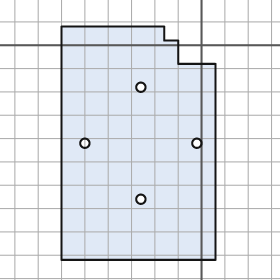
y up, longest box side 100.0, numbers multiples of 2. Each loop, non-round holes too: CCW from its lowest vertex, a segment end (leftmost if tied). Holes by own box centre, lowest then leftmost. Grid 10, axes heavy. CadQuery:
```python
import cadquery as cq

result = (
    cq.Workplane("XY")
    .moveTo(-60.0, -92.0)
    .lineTo(6.0, -92.0)
    .lineTo(6.0, -8.0)
    .lineTo(-10.0, -8.0)
    .lineTo(-10.0, 2.0)
    .lineTo(-16.0, 2.0)
    .lineTo(-16.0, 8.0)
    .lineTo(-60.0, 8.0)
    .close()
    .moveTo(-26.0, -66.0)
    .circle(2.0)
    .moveTo(-50.0, -42.0)
    .circle(2.0)
    .moveTo(-2.0, -42.0)
    .circle(2.0)
    .moveTo(-26.0, -18.0)
    .circle(2.0)
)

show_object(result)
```